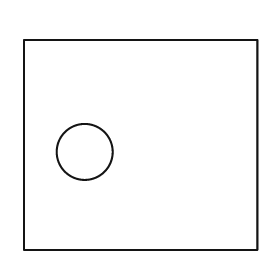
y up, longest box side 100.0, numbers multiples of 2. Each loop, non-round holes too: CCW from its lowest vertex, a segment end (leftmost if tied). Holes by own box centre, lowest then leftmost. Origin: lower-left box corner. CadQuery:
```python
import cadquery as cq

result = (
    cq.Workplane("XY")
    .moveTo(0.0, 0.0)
    .lineTo(100.0, 0.0)
    .lineTo(100.0, 90.0)
    .lineTo(0.0, 90.0)
    .close()
    .moveTo(26.0, 42.0)
    .circle(12.0)
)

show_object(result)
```